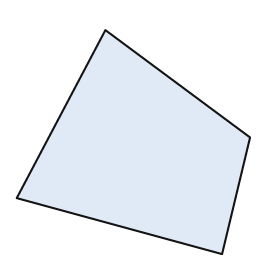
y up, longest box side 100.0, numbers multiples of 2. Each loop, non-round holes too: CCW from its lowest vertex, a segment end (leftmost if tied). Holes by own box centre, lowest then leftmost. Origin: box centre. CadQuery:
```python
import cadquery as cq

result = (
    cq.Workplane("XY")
    .moveTo(38.0, -48.0)
    .lineTo(50.0, 2.0)
    .lineTo(-12.0, 48.0)
    .lineTo(-50.0, -24.0)
    .close()
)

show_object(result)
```